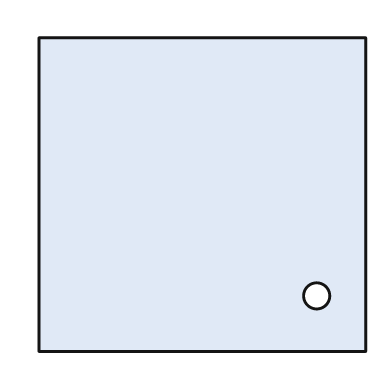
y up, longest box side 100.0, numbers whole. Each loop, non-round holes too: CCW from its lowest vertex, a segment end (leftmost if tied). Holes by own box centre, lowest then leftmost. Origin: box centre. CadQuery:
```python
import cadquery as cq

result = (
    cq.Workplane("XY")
    .moveTo(-50.0, -48.0)
    .lineTo(50.0, -48.0)
    .lineTo(50.0, 48.0)
    .lineTo(-50.0, 48.0)
    .close()
    .moveTo(35.0, -31.0)
    .circle(4.0)
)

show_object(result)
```